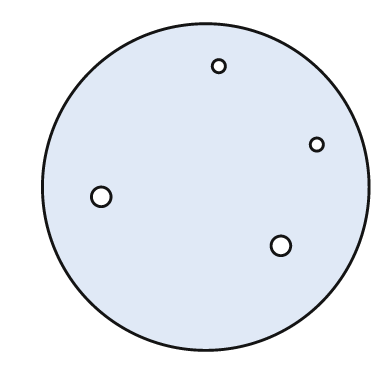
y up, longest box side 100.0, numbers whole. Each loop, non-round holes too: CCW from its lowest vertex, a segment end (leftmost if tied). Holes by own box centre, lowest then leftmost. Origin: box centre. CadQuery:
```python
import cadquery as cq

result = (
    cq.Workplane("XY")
    .moveTo(0.0, 0.0)
    .circle(50.0)
    .moveTo(23.0, -18.0)
    .circle(3.0)
    .moveTo(-32.0, -3.0)
    .circle(3.0)
    .moveTo(34.0, 13.0)
    .circle(2.0)
    .moveTo(4.0, 37.0)
    .circle(2.0)
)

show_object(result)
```